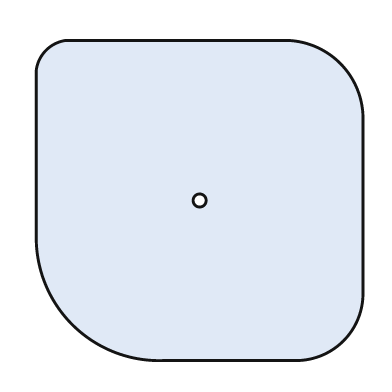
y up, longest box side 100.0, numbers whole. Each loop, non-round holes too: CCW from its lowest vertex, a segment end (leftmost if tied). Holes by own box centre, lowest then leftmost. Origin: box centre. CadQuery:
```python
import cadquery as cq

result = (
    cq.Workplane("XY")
    .moveTo(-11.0, -49.0)
    .lineTo(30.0, -49.0)
    .threePointArc((44.0, -43.0), (50.0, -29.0))
    .lineTo(50.0, 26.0)
    .threePointArc((43.0, 42.0), (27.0, 49.0))
    .lineTo(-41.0, 49.0)
    .threePointArc((-47.0, 46.0), (-50.0, 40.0))
    .lineTo(-50.0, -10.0)
    .threePointArc((-39.0, -38.0), (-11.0, -49.0))
    .close()
    .moveTo(0.0, 0.0)
    .circle(2.0)
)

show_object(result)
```